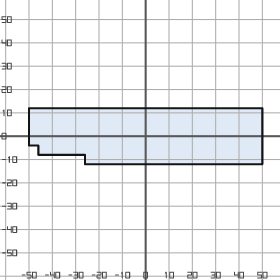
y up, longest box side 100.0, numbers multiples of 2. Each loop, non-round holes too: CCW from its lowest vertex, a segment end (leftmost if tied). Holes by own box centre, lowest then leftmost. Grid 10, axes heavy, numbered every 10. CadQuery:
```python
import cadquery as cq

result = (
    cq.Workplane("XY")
    .moveTo(-26.0, -12.0)
    .lineTo(50.0, -12.0)
    .lineTo(50.0, 12.0)
    .lineTo(-50.0, 12.0)
    .lineTo(-50.0, -4.0)
    .lineTo(-46.0, -4.0)
    .lineTo(-46.0, -8.0)
    .lineTo(-26.0, -8.0)
    .close()
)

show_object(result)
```